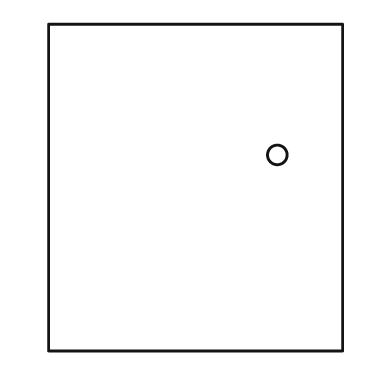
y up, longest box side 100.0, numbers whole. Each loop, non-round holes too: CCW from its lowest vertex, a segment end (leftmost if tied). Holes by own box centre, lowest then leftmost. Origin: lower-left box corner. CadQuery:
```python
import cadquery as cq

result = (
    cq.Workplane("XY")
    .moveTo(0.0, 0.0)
    .lineTo(90.0, 0.0)
    .lineTo(90.0, 100.0)
    .lineTo(0.0, 100.0)
    .close()
    .moveTo(70.0, 60.0)
    .circle(3.0)
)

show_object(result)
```